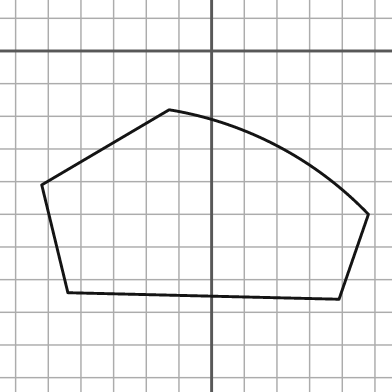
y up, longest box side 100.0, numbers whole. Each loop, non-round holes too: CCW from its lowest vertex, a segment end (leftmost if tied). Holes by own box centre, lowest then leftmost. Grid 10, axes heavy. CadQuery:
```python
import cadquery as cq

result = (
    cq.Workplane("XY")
    .moveTo(39.0, -76.0)
    .lineTo(48.0, -50.0)
    .threePointArc((20.0, -29.0), (-13.0, -18.0))
    .lineTo(-52.0, -41.0)
    .lineTo(-44.0, -74.0)
    .close()
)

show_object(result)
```